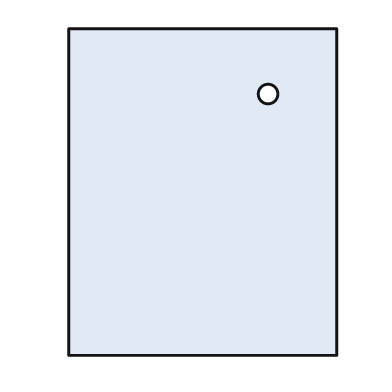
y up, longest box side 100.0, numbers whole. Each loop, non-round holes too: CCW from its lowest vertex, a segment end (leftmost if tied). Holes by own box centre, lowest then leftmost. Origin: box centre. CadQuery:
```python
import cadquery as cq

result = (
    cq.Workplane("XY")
    .moveTo(-41.0, -50.0)
    .lineTo(41.0, -50.0)
    .lineTo(41.0, 50.0)
    .lineTo(-41.0, 50.0)
    .close()
    .moveTo(20.0, 30.0)
    .circle(3.0)
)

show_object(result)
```